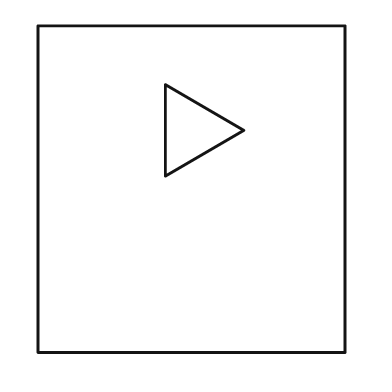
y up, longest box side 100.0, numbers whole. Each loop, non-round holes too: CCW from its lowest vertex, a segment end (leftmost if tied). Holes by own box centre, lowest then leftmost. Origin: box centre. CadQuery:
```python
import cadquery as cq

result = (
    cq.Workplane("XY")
    .moveTo(-47.0, -50.0)
    .lineTo(47.0, -50.0)
    .lineTo(47.0, 50.0)
    .lineTo(-47.0, 50.0)
    .close()
    .moveTo(-8.0, 4.0)
    .lineTo(16.0, 18.0)
    .lineTo(-8.0, 32.0)
    .close()
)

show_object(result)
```